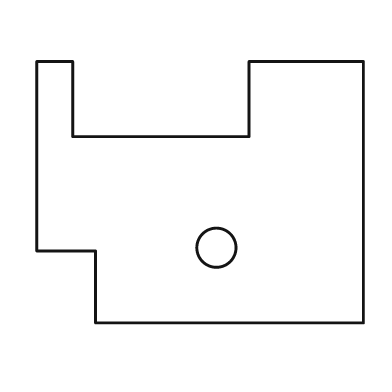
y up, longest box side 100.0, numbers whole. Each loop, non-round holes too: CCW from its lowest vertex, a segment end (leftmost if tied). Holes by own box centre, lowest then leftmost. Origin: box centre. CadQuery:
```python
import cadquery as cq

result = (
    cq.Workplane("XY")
    .moveTo(-32.0, -40.0)
    .lineTo(50.0, -40.0)
    .lineTo(50.0, 40.0)
    .lineTo(15.0, 40.0)
    .lineTo(15.0, 17.0)
    .lineTo(-39.0, 17.0)
    .lineTo(-39.0, 40.0)
    .lineTo(-50.0, 40.0)
    .lineTo(-50.0, -18.0)
    .lineTo(-32.0, -18.0)
    .close()
    .moveTo(5.0, -17.0)
    .circle(6.0)
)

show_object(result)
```